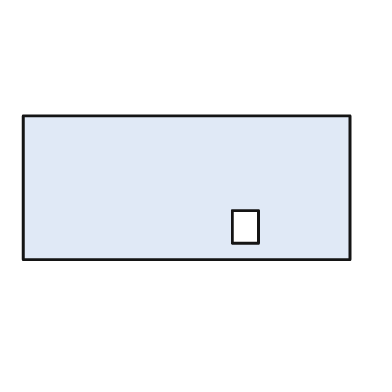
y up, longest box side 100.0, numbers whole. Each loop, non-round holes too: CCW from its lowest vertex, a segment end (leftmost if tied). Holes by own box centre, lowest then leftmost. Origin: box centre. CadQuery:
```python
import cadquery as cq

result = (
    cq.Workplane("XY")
    .moveTo(-50.0, -22.0)
    .lineTo(50.0, -22.0)
    .lineTo(50.0, 22.0)
    .lineTo(-50.0, 22.0)
    .close()
    .moveTo(14.0, -17.0)
    .lineTo(22.0, -17.0)
    .lineTo(22.0, -7.0)
    .lineTo(14.0, -7.0)
    .close()
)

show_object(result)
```